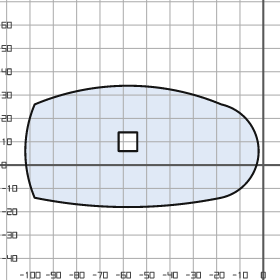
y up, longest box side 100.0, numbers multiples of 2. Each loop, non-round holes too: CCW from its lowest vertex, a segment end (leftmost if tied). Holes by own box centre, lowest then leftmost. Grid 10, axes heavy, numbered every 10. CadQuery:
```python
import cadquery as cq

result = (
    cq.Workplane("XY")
    .moveTo(-98.0, -14.0)
    .threePointArc((-58.0, -18.0), (-18.0, -14.0))
    .threePointArc((-2.0, 6.0), (-18.0, 26.0))
    .threePointArc((-58.0, 34.0), (-98.0, 26.0))
    .threePointArc((-102.0, 6.0), (-98.0, -14.0))
    .close()
    .moveTo(-62.0, 6.0)
    .lineTo(-54.0, 6.0)
    .lineTo(-54.0, 14.0)
    .lineTo(-62.0, 14.0)
    .close()
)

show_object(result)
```